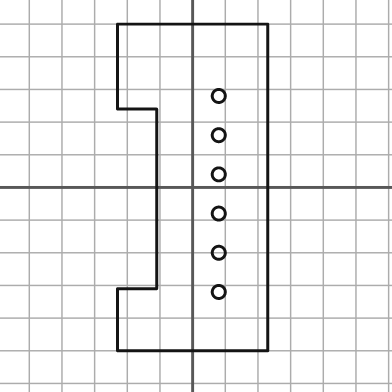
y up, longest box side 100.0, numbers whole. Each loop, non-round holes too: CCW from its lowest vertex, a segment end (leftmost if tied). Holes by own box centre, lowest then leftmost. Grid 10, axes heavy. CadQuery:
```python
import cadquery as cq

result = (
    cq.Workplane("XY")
    .moveTo(-23.0, -50.0)
    .lineTo(23.0, -50.0)
    .lineTo(23.0, 50.0)
    .lineTo(-23.0, 50.0)
    .lineTo(-23.0, 24.0)
    .lineTo(-11.0, 24.0)
    .lineTo(-11.0, -31.0)
    .lineTo(-23.0, -31.0)
    .close()
    .moveTo(8.0, -32.0)
    .circle(2.0)
    .moveTo(8.0, -20.0)
    .circle(2.0)
    .moveTo(8.0, -8.0)
    .circle(2.0)
    .moveTo(8.0, 4.0)
    .circle(2.0)
    .moveTo(8.0, 16.0)
    .circle(2.0)
    .moveTo(8.0, 28.0)
    .circle(2.0)
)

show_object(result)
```